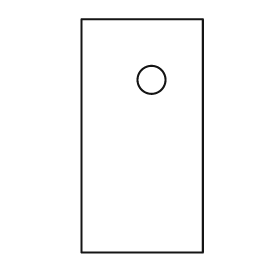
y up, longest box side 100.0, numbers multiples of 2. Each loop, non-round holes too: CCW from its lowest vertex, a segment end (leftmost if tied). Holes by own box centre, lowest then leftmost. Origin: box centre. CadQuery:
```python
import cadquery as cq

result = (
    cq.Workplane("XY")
    .moveTo(-26.0, -50.0)
    .lineTo(26.0, -50.0)
    .lineTo(26.0, 50.0)
    .lineTo(-26.0, 50.0)
    .close()
    .moveTo(4.0, 24.0)
    .circle(6.0)
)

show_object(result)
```